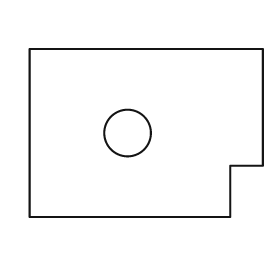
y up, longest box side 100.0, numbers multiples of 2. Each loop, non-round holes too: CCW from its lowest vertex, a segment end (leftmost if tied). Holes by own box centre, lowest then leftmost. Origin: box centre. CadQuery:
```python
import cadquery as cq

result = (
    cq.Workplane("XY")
    .moveTo(-50.0, -36.0)
    .lineTo(36.0, -36.0)
    .lineTo(36.0, -14.0)
    .lineTo(50.0, -14.0)
    .lineTo(50.0, 36.0)
    .lineTo(-50.0, 36.0)
    .close()
    .moveTo(-8.0, 0.0)
    .circle(10.0)
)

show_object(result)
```